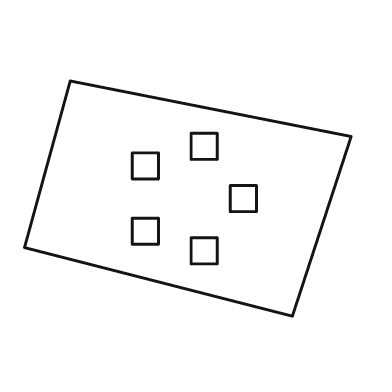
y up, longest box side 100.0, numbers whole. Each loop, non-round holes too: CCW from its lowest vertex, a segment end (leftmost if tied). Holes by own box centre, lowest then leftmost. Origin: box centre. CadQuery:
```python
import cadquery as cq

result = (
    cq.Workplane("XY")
    .moveTo(32.0, -36.0)
    .lineTo(50.0, 19.0)
    .lineTo(-36.0, 36.0)
    .lineTo(-50.0, -15.0)
    .close()
    .moveTo(1.0, -20.0)
    .lineTo(9.0, -20.0)
    .lineTo(9.0, -12.0)
    .lineTo(1.0, -12.0)
    .close()
    .moveTo(-17.0, -14.0)
    .lineTo(-9.0, -14.0)
    .lineTo(-9.0, -6.0)
    .lineTo(-17.0, -6.0)
    .close()
    .moveTo(13.0, -4.0)
    .lineTo(21.0, -4.0)
    .lineTo(21.0, 4.0)
    .lineTo(13.0, 4.0)
    .close()
    .moveTo(-17.0, 6.0)
    .lineTo(-9.0, 6.0)
    .lineTo(-9.0, 14.0)
    .lineTo(-17.0, 14.0)
    .close()
    .moveTo(1.0, 12.0)
    .lineTo(9.0, 12.0)
    .lineTo(9.0, 20.0)
    .lineTo(1.0, 20.0)
    .close()
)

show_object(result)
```